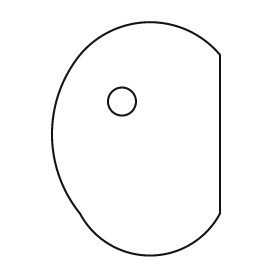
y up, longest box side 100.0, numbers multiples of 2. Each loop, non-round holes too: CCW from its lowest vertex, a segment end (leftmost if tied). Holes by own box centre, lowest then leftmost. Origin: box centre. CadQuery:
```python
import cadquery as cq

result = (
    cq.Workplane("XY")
    .moveTo(-24.0, -32.0)
    .threePointArc((6.0, -50.0), (36.0, -32.0))
    .lineTo(36.0, 36.0)
    .threePointArc((6.0, 50.0), (-24.0, 36.0))
    .threePointArc((-36.0, 2.0), (-24.0, -32.0))
    .close()
    .moveTo(-6.0, 16.0)
    .circle(6.0)
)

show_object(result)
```